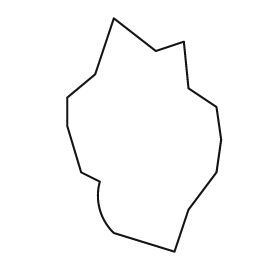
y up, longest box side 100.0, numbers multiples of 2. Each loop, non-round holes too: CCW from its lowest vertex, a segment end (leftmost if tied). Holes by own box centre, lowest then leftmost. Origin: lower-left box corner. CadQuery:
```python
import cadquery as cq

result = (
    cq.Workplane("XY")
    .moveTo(46.0, 0.0)
    .lineTo(52.0, 18.0)
    .lineTo(64.0, 34.0)
    .lineTo(66.0, 48.0)
    .lineTo(64.0, 62.0)
    .lineTo(52.0, 70.0)
    .lineTo(50.0, 90.0)
    .lineTo(38.0, 86.0)
    .lineTo(20.0, 100.0)
    .lineTo(12.0, 76.0)
    .lineTo(0.0, 66.0)
    .lineTo(0.0, 54.0)
    .lineTo(6.0, 34.0)
    .lineTo(14.0, 30.0)
    .threePointArc((14.0, 18.0), (20.0, 8.0))
    .close()
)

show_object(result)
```